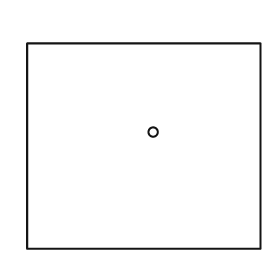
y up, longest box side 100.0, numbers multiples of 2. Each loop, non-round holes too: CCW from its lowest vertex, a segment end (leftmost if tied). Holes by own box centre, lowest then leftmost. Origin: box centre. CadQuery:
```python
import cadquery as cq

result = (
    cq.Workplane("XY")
    .moveTo(-50.0, -44.0)
    .lineTo(50.0, -44.0)
    .lineTo(50.0, 44.0)
    .lineTo(-50.0, 44.0)
    .close()
    .moveTo(4.0, 6.0)
    .circle(2.0)
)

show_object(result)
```